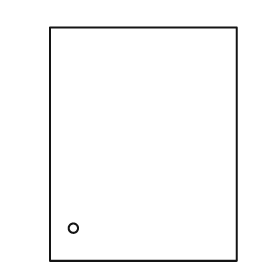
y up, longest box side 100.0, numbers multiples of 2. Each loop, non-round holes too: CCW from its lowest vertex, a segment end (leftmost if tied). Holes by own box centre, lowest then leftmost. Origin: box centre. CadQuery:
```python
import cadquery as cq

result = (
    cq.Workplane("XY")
    .moveTo(-40.0, -50.0)
    .lineTo(40.0, -50.0)
    .lineTo(40.0, 50.0)
    .lineTo(-40.0, 50.0)
    .close()
    .moveTo(-30.0, -36.0)
    .circle(2.0)
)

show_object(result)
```